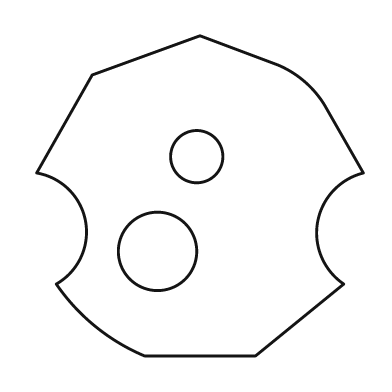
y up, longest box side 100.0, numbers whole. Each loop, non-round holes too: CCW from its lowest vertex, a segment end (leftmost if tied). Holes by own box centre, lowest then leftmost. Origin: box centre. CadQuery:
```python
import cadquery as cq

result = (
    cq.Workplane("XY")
    .moveTo(-17.0, -49.0)
    .lineTo(17.0, -49.0)
    .lineTo(44.0, -27.0)
    .threePointArc((36.0, -8.0), (50.0, 7.0))
    .lineTo(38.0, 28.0)
    .threePointArc((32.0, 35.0), (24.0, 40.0))
    .lineTo(0.0, 49.0)
    .lineTo(-33.0, 37.0)
    .lineTo(-50.0, 7.0)
    .threePointArc((-35.0, -8.0), (-44.0, -27.0))
    .threePointArc((-32.0, -40.0), (-17.0, -49.0))
    .close()
    .moveTo(-13.0, -17.0)
    .circle(12.0)
    .moveTo(-1.0, 12.0)
    .circle(8.0)
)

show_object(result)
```